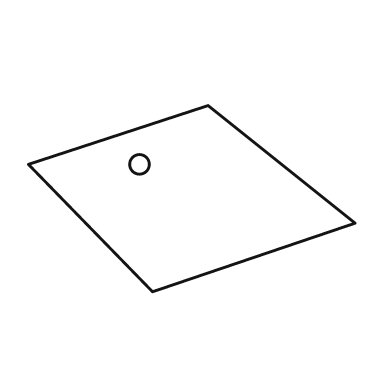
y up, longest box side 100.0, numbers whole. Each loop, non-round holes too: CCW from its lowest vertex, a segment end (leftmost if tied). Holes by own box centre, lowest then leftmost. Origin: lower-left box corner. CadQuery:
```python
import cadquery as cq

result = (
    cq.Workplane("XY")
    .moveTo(38.0, 0.0)
    .lineTo(100.0, 21.0)
    .lineTo(55.0, 57.0)
    .lineTo(0.0, 39.0)
    .close()
    .moveTo(34.0, 39.0)
    .circle(3.0)
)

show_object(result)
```